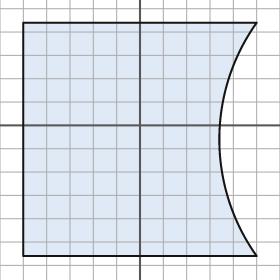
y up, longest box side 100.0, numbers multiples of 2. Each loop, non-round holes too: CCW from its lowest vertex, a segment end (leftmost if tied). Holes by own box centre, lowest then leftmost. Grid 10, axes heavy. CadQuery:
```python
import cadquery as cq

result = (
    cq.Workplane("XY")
    .moveTo(-50.0, -56.0)
    .lineTo(50.0, -56.0)
    .threePointArc((34.0, -6.0), (50.0, 44.0))
    .lineTo(-50.0, 44.0)
    .close()
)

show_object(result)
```